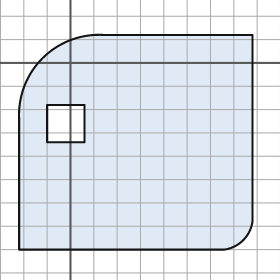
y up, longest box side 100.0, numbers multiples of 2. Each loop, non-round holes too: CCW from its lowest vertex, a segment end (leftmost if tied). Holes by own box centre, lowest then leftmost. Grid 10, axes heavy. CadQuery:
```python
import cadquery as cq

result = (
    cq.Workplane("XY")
    .moveTo(-22.0, -80.0)
    .lineTo(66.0, -80.0)
    .threePointArc((74.0, -76.0), (78.0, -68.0))
    .lineTo(78.0, 12.0)
    .lineTo(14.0, 12.0)
    .threePointArc((-12.0, 2.0), (-22.0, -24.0))
    .close()
    .moveTo(-10.0, -34.0)
    .lineTo(6.0, -34.0)
    .lineTo(6.0, -18.0)
    .lineTo(-10.0, -18.0)
    .close()
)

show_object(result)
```